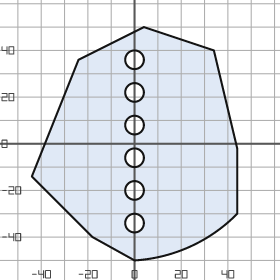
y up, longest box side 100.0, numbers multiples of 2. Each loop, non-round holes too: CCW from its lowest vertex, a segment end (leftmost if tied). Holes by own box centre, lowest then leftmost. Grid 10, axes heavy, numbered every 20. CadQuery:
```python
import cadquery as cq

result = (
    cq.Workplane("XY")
    .moveTo(0.0, -50.0)
    .threePointArc((24.0, -44.0), (44.0, -30.0))
    .lineTo(44.0, -2.0)
    .lineTo(34.0, 40.0)
    .lineTo(4.0, 50.0)
    .lineTo(-24.0, 36.0)
    .lineTo(-44.0, -14.0)
    .lineTo(-18.0, -40.0)
    .close()
    .moveTo(0.0, -34.0)
    .circle(4.0)
    .moveTo(0.0, -20.0)
    .circle(4.0)
    .moveTo(0.0, -6.0)
    .circle(4.0)
    .moveTo(0.0, 8.0)
    .circle(4.0)
    .moveTo(0.0, 22.0)
    .circle(4.0)
    .moveTo(0.0, 36.0)
    .circle(4.0)
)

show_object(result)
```